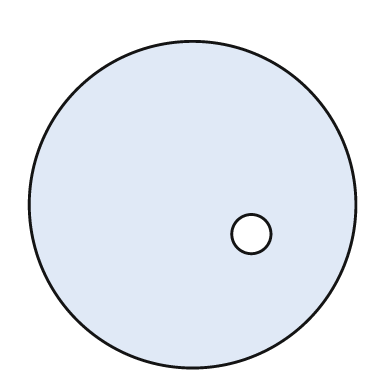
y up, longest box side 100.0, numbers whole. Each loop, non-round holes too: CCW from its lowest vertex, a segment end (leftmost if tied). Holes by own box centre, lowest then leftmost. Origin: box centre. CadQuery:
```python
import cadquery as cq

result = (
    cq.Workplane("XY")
    .moveTo(0.0, 0.0)
    .circle(50.0)
    .moveTo(18.0, -9.0)
    .circle(6.0)
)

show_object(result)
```